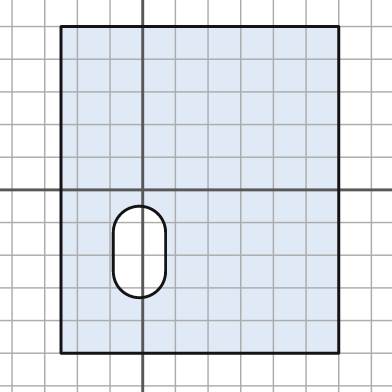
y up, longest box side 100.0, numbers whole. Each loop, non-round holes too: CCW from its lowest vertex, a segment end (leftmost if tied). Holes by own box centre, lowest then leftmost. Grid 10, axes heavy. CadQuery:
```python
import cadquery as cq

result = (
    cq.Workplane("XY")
    .moveTo(-25.0, -50.0)
    .lineTo(60.0, -50.0)
    .lineTo(60.0, 50.0)
    .lineTo(-25.0, 50.0)
    .close()
    .moveTo(-9.0, -25.0)
    .threePointArc((-1.0, -33.0), (7.0, -25.0))
    .lineTo(7.0, -13.0)
    .threePointArc((-1.0, -5.0), (-9.0, -13.0))
    .close()
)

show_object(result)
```